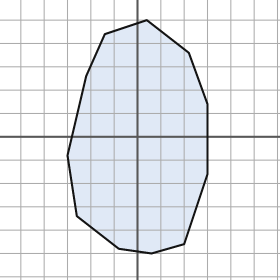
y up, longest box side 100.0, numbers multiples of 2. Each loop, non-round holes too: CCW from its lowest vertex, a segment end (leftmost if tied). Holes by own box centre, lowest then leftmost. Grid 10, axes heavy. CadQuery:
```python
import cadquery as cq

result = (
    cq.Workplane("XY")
    .moveTo(6.0, -50.0)
    .lineTo(20.0, -46.0)
    .lineTo(30.0, -16.0)
    .lineTo(30.0, 14.0)
    .lineTo(22.0, 36.0)
    .lineTo(4.0, 50.0)
    .lineTo(-14.0, 44.0)
    .lineTo(-22.0, 26.0)
    .lineTo(-30.0, -8.0)
    .lineTo(-26.0, -34.0)
    .lineTo(-8.0, -48.0)
    .close()
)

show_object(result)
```